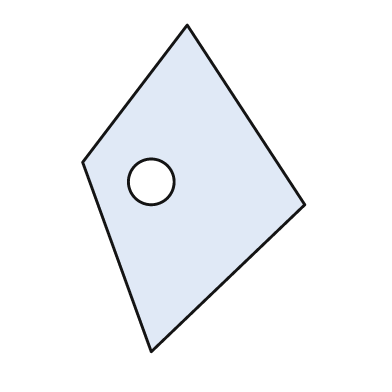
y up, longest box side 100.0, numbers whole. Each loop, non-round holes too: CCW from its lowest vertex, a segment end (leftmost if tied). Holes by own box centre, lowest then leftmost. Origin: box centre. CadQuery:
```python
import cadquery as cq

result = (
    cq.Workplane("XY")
    .moveTo(-13.0, -50.0)
    .lineTo(34.0, -5.0)
    .lineTo(-2.0, 50.0)
    .lineTo(-34.0, 8.0)
    .close()
    .moveTo(-13.0, 2.0)
    .circle(7.0)
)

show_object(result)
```